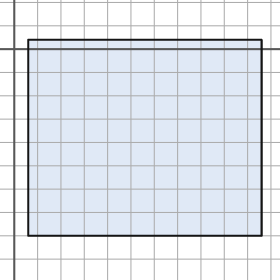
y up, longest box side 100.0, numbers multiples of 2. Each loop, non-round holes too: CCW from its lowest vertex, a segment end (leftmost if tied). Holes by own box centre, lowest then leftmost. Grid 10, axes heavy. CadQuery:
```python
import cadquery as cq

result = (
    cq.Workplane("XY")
    .moveTo(6.0, -80.0)
    .lineTo(106.0, -80.0)
    .lineTo(106.0, 4.0)
    .lineTo(6.0, 4.0)
    .close()
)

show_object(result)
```